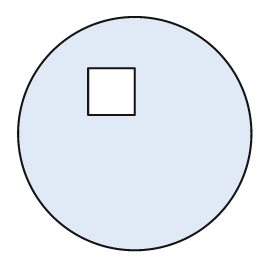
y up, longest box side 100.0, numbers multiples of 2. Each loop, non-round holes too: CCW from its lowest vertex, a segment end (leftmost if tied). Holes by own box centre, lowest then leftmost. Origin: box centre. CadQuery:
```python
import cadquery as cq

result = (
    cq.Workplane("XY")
    .moveTo(0.0, 0.0)
    .circle(50.0)
    .moveTo(-20.0, 8.0)
    .lineTo(0.0, 8.0)
    .lineTo(0.0, 28.0)
    .lineTo(-20.0, 28.0)
    .close()
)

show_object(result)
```